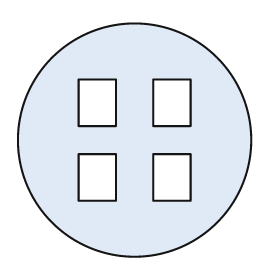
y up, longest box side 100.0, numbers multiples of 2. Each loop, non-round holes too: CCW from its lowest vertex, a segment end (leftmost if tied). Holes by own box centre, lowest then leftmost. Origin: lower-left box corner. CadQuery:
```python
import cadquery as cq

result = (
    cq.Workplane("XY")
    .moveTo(50.0, 50.0)
    .circle(50.0)
    .moveTo(26.0, 24.0)
    .lineTo(42.0, 24.0)
    .lineTo(42.0, 44.0)
    .lineTo(26.0, 44.0)
    .close()
    .moveTo(58.0, 24.0)
    .lineTo(74.0, 24.0)
    .lineTo(74.0, 44.0)
    .lineTo(58.0, 44.0)
    .close()
    .moveTo(26.0, 56.0)
    .lineTo(42.0, 56.0)
    .lineTo(42.0, 76.0)
    .lineTo(26.0, 76.0)
    .close()
    .moveTo(58.0, 56.0)
    .lineTo(74.0, 56.0)
    .lineTo(74.0, 76.0)
    .lineTo(58.0, 76.0)
    .close()
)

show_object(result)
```